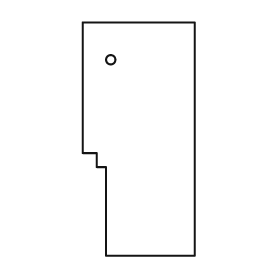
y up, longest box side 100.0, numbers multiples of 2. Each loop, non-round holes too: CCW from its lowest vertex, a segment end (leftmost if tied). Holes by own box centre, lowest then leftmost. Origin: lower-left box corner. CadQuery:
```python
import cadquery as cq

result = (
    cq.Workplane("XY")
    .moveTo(10.0, 0.0)
    .lineTo(48.0, 0.0)
    .lineTo(48.0, 100.0)
    .lineTo(0.0, 100.0)
    .lineTo(0.0, 44.0)
    .lineTo(6.0, 44.0)
    .lineTo(6.0, 38.0)
    .lineTo(10.0, 38.0)
    .close()
    .moveTo(12.0, 84.0)
    .circle(2.0)
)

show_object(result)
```